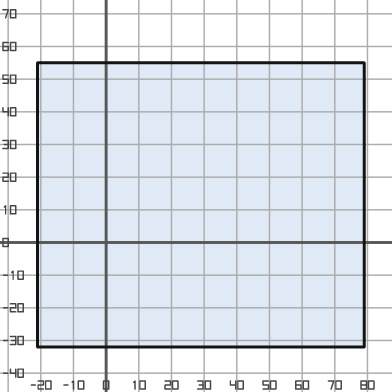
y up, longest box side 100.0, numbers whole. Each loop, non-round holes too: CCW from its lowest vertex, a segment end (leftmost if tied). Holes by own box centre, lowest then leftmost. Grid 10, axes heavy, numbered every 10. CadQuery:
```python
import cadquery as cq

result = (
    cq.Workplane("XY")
    .moveTo(-21.0, -32.0)
    .lineTo(79.0, -32.0)
    .lineTo(79.0, 55.0)
    .lineTo(-21.0, 55.0)
    .close()
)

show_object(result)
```